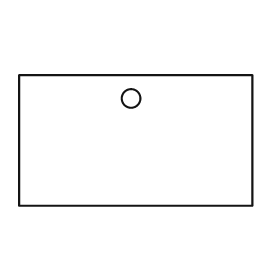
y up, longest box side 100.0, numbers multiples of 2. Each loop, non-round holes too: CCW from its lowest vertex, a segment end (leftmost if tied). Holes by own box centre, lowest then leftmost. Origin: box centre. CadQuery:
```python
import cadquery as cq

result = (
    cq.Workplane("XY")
    .moveTo(-50.0, -28.0)
    .lineTo(50.0, -28.0)
    .lineTo(50.0, 28.0)
    .lineTo(-50.0, 28.0)
    .close()
    .moveTo(-2.0, 18.0)
    .circle(4.0)
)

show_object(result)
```